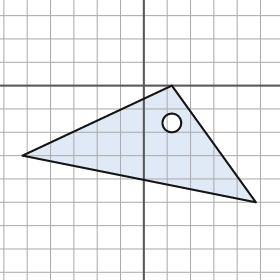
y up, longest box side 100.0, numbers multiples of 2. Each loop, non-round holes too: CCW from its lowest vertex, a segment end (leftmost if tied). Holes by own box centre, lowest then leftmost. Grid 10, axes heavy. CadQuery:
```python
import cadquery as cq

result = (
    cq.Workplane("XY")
    .moveTo(48.0, -50.0)
    .lineTo(12.0, 0.0)
    .lineTo(-52.0, -30.0)
    .close()
    .moveTo(12.0, -16.0)
    .circle(4.0)
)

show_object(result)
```